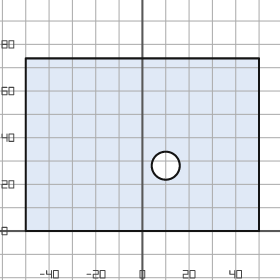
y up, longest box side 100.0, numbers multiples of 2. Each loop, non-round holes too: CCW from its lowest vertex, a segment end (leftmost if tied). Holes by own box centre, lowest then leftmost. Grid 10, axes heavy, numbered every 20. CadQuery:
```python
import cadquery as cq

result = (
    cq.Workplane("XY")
    .moveTo(-50.0, 0.0)
    .lineTo(50.0, 0.0)
    .lineTo(50.0, 74.0)
    .lineTo(-50.0, 74.0)
    .close()
    .moveTo(10.0, 28.0)
    .circle(6.0)
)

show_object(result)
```